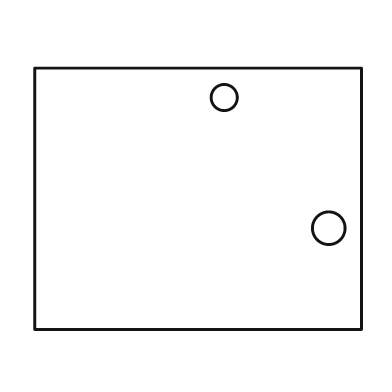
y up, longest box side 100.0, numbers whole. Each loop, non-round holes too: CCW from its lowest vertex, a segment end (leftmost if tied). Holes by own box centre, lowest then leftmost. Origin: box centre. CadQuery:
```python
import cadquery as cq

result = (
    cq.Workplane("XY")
    .moveTo(-50.0, -40.0)
    .lineTo(50.0, -40.0)
    .lineTo(50.0, 40.0)
    .lineTo(-50.0, 40.0)
    .close()
    .moveTo(40.0, -9.0)
    .circle(5.0)
    .moveTo(8.0, 31.0)
    .circle(4.0)
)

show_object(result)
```